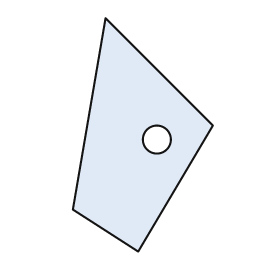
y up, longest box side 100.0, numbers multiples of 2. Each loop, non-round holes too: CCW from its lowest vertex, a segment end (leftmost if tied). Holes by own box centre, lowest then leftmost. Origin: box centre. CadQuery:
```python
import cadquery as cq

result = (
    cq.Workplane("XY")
    .moveTo(-2.0, -50.0)
    .lineTo(30.0, 4.0)
    .lineTo(-16.0, 50.0)
    .lineTo(-30.0, -32.0)
    .close()
    .moveTo(6.0, -2.0)
    .circle(6.0)
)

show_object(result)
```